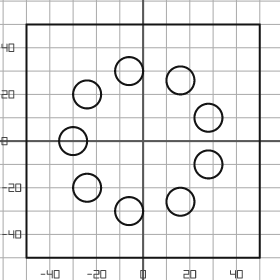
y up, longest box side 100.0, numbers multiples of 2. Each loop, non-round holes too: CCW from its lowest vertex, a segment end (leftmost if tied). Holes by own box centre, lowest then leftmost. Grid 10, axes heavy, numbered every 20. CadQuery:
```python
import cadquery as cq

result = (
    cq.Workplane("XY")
    .moveTo(-50.0, -50.0)
    .lineTo(50.0, -50.0)
    .lineTo(50.0, 50.0)
    .lineTo(-50.0, 50.0)
    .close()
    .moveTo(-6.0, -30.0)
    .circle(6.0)
    .moveTo(16.0, -26.0)
    .circle(6.0)
    .moveTo(-24.0, -20.0)
    .circle(6.0)
    .moveTo(28.0, -10.0)
    .circle(6.0)
    .moveTo(-30.0, 0.0)
    .circle(6.0)
    .moveTo(28.0, 10.0)
    .circle(6.0)
    .moveTo(-24.0, 20.0)
    .circle(6.0)
    .moveTo(16.0, 26.0)
    .circle(6.0)
    .moveTo(-6.0, 30.0)
    .circle(6.0)
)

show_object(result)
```